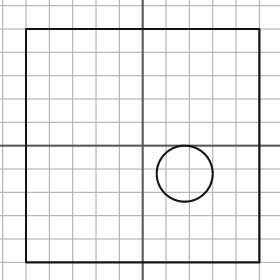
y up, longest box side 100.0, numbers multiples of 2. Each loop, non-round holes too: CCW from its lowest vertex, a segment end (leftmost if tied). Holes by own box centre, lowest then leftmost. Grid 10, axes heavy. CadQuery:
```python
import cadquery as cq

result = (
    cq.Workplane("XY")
    .moveTo(-50.0, -50.0)
    .lineTo(50.0, -50.0)
    .lineTo(50.0, 50.0)
    .lineTo(-50.0, 50.0)
    .close()
    .moveTo(18.0, -12.0)
    .circle(12.0)
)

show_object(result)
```